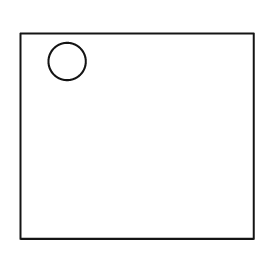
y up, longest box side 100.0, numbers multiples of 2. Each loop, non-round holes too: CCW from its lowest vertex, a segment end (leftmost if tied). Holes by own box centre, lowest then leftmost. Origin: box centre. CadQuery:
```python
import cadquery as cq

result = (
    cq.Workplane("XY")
    .moveTo(-50.0, -44.0)
    .lineTo(50.0, -44.0)
    .lineTo(50.0, 44.0)
    .lineTo(-50.0, 44.0)
    .close()
    .moveTo(-30.0, 32.0)
    .circle(8.0)
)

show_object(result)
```